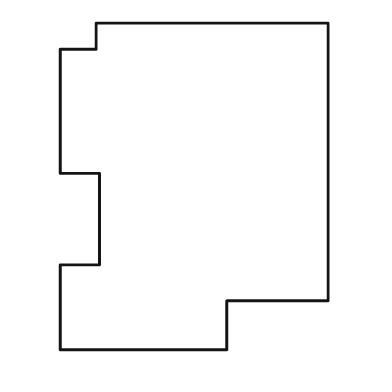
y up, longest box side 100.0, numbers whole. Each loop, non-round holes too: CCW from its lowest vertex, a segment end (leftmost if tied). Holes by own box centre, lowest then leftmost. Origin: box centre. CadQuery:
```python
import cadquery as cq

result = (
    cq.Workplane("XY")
    .moveTo(-41.0, -50.0)
    .lineTo(10.0, -50.0)
    .lineTo(10.0, -35.0)
    .lineTo(41.0, -35.0)
    .lineTo(41.0, 50.0)
    .lineTo(-30.0, 50.0)
    .lineTo(-30.0, 42.0)
    .lineTo(-41.0, 42.0)
    .lineTo(-41.0, 4.0)
    .lineTo(-29.0, 4.0)
    .lineTo(-29.0, -24.0)
    .lineTo(-41.0, -24.0)
    .close()
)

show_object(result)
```